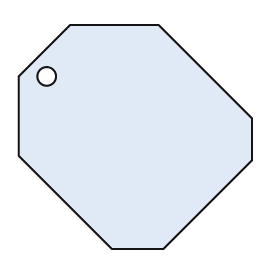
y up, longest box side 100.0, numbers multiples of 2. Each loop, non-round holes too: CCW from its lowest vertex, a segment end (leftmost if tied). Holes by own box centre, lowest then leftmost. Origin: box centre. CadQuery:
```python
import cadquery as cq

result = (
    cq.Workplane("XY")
    .moveTo(-10.0, -48.0)
    .lineTo(12.0, -48.0)
    .lineTo(50.0, -10.0)
    .lineTo(50.0, 8.0)
    .lineTo(10.0, 48.0)
    .lineTo(-28.0, 48.0)
    .lineTo(-50.0, 26.0)
    .lineTo(-50.0, -8.0)
    .close()
    .moveTo(-38.0, 26.0)
    .circle(4.0)
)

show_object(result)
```